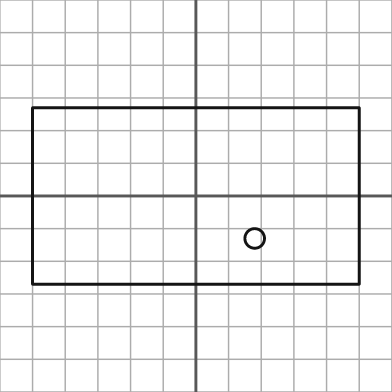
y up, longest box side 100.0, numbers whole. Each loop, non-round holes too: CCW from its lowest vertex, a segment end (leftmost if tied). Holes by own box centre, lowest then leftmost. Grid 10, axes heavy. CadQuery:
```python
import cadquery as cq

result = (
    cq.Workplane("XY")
    .moveTo(-50.0, -27.0)
    .lineTo(50.0, -27.0)
    .lineTo(50.0, 27.0)
    .lineTo(-50.0, 27.0)
    .close()
    .moveTo(18.0, -13.0)
    .circle(3.0)
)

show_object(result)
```